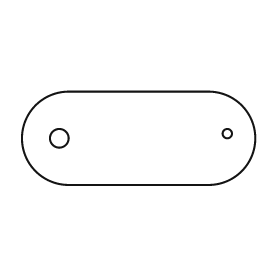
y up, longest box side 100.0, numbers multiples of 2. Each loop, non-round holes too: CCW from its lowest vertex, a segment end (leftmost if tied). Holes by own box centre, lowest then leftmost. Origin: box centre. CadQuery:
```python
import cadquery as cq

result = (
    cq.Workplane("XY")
    .moveTo(-30.0, -20.0)
    .lineTo(30.0, -20.0)
    .threePointArc((50.0, 0.0), (30.0, 20.0))
    .lineTo(-30.0, 20.0)
    .threePointArc((-50.0, 0.0), (-30.0, -20.0))
    .close()
    .moveTo(-34.0, 0.0)
    .circle(4.0)
    .moveTo(38.0, 2.0)
    .circle(2.0)
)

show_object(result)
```